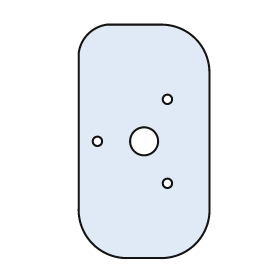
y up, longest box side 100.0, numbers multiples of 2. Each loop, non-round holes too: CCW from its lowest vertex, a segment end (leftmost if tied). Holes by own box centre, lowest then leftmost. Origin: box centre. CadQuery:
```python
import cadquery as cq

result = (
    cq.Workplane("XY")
    .moveTo(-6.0, -50.0)
    .lineTo(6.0, -50.0)
    .threePointArc((22.0, -44.0), (28.0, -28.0))
    .lineTo(28.0, 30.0)
    .threePointArc((22.0, 44.0), (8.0, 50.0))
    .lineTo(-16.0, 50.0)
    .threePointArc((-24.0, 46.0), (-28.0, 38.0))
    .lineTo(-28.0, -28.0)
    .threePointArc((-22.0, -44.0), (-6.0, -50.0))
    .close()
    .moveTo(10.0, -18.0)
    .circle(2.0)
    .moveTo(-20.0, 0.0)
    .circle(2.0)
    .moveTo(0.0, 0.0)
    .circle(6.0)
    .moveTo(10.0, 18.0)
    .circle(2.0)
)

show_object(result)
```